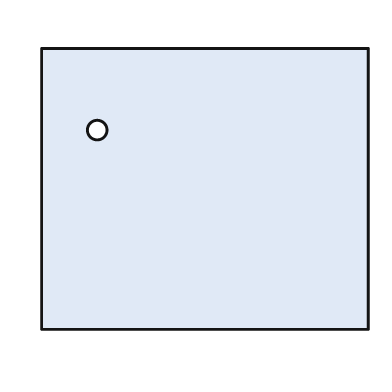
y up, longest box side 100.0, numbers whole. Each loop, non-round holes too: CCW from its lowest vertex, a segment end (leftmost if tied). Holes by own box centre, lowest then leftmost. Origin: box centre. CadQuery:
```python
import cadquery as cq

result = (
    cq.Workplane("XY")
    .moveTo(-50.0, -43.0)
    .lineTo(50.0, -43.0)
    .lineTo(50.0, 43.0)
    .lineTo(-50.0, 43.0)
    .close()
    .moveTo(-33.0, 18.0)
    .circle(3.0)
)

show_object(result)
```